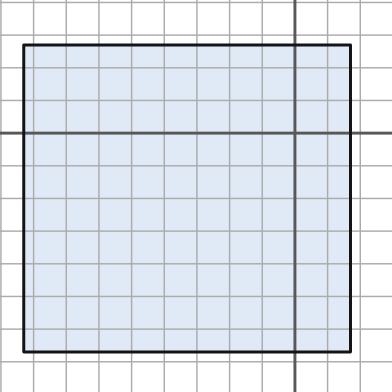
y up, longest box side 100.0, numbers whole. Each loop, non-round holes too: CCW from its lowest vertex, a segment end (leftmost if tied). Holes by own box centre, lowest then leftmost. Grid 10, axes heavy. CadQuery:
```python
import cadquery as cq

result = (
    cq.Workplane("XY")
    .moveTo(-83.0, -67.0)
    .lineTo(17.0, -67.0)
    .lineTo(17.0, 27.0)
    .lineTo(-83.0, 27.0)
    .close()
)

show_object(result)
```